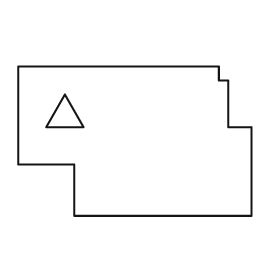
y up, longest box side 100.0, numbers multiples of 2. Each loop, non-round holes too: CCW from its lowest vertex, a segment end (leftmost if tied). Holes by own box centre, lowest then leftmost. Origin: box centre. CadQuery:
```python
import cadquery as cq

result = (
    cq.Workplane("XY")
    .moveTo(-26.0, -32.0)
    .lineTo(50.0, -32.0)
    .lineTo(50.0, 6.0)
    .lineTo(40.0, 6.0)
    .lineTo(40.0, 26.0)
    .lineTo(36.0, 26.0)
    .lineTo(36.0, 32.0)
    .lineTo(-50.0, 32.0)
    .lineTo(-50.0, -10.0)
    .lineTo(-26.0, -10.0)
    .close()
    .moveTo(-38.0, 6.0)
    .lineTo(-22.0, 6.0)
    .lineTo(-30.0, 20.0)
    .close()
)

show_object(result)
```